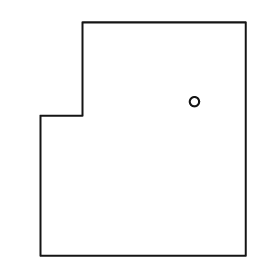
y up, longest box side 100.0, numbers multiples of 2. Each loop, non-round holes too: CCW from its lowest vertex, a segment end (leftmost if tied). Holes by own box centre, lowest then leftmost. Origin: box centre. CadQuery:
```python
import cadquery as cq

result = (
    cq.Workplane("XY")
    .moveTo(-44.0, -50.0)
    .lineTo(44.0, -50.0)
    .lineTo(44.0, 50.0)
    .lineTo(-26.0, 50.0)
    .lineTo(-26.0, 10.0)
    .lineTo(-44.0, 10.0)
    .close()
    .moveTo(22.0, 16.0)
    .circle(2.0)
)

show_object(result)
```